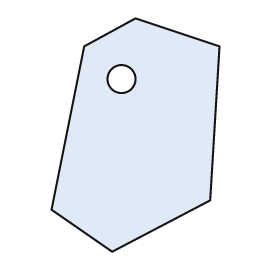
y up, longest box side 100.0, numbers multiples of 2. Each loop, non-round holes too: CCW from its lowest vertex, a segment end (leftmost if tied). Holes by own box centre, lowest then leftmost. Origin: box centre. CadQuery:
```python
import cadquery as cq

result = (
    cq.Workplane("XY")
    .moveTo(-10.0, -50.0)
    .lineTo(32.0, -28.0)
    .lineTo(36.0, 38.0)
    .lineTo(0.0, 50.0)
    .lineTo(-22.0, 38.0)
    .lineTo(-36.0, -32.0)
    .close()
    .moveTo(-6.0, 24.0)
    .circle(6.0)
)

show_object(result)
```